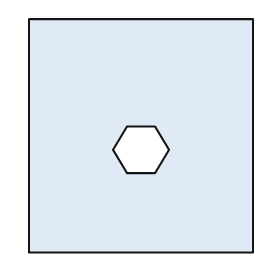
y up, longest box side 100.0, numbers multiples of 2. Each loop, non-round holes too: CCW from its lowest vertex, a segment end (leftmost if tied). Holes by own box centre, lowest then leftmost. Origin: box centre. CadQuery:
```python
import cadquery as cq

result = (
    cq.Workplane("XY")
    .moveTo(-48.0, -50.0)
    .lineTo(48.0, -50.0)
    .lineTo(48.0, 50.0)
    .lineTo(-48.0, 50.0)
    .close()
    .moveTo(-6.0, -16.0)
    .lineTo(6.0, -16.0)
    .lineTo(12.0, -6.0)
    .lineTo(6.0, 4.0)
    .lineTo(-6.0, 4.0)
    .lineTo(-12.0, -6.0)
    .close()
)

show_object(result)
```